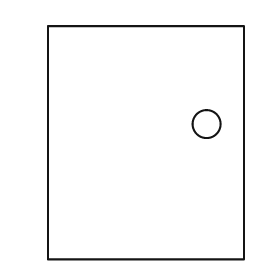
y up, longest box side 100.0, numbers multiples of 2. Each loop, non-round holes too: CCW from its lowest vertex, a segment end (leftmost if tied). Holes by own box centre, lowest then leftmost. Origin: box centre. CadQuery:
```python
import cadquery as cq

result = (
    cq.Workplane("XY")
    .moveTo(-42.0, -50.0)
    .lineTo(42.0, -50.0)
    .lineTo(42.0, 50.0)
    .lineTo(-42.0, 50.0)
    .close()
    .moveTo(26.0, 8.0)
    .circle(6.0)
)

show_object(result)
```